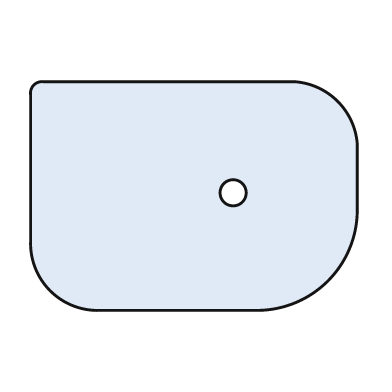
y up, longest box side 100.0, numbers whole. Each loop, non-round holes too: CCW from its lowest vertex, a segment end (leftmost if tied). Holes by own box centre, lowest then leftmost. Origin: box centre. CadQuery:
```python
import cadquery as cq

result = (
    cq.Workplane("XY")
    .moveTo(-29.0, -35.0)
    .lineTo(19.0, -35.0)
    .threePointArc((41.0, -26.0), (50.0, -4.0))
    .lineTo(50.0, 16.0)
    .threePointArc((44.0, 29.0), (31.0, 35.0))
    .lineTo(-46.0, 35.0)
    .threePointArc((-49.0, 34.0), (-50.0, 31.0))
    .lineTo(-50.0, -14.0)
    .threePointArc((-44.0, -29.0), (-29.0, -35.0))
    .close()
    .moveTo(12.0, 1.0)
    .circle(4.0)
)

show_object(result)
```